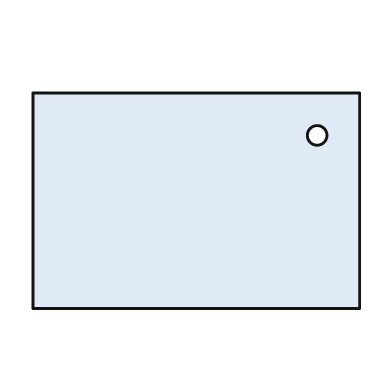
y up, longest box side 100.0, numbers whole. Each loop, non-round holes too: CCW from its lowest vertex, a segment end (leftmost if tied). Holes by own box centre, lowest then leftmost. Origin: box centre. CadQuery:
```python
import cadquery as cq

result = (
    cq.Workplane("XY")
    .moveTo(-50.0, -33.0)
    .lineTo(50.0, -33.0)
    .lineTo(50.0, 33.0)
    .lineTo(-50.0, 33.0)
    .close()
    .moveTo(37.0, 20.0)
    .circle(3.0)
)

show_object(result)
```